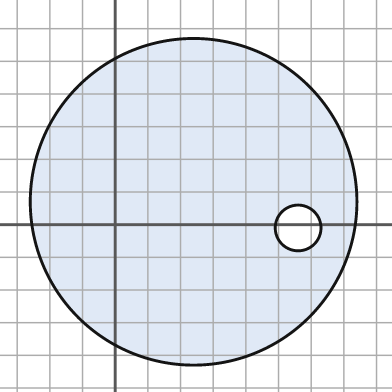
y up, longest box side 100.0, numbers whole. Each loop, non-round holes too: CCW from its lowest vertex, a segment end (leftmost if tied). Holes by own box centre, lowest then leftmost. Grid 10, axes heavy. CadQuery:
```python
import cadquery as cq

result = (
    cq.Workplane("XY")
    .moveTo(24.0, 7.0)
    .circle(50.0)
    .moveTo(56.0, -1.0)
    .circle(7.0)
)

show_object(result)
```